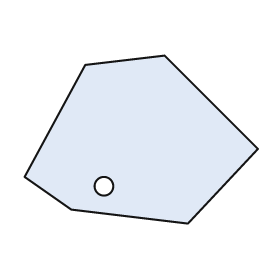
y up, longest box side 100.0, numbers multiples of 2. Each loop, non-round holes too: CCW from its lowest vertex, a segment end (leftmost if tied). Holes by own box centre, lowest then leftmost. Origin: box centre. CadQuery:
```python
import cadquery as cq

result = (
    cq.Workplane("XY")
    .moveTo(20.0, -36.0)
    .lineTo(50.0, -4.0)
    .lineTo(10.0, 36.0)
    .lineTo(-24.0, 32.0)
    .lineTo(-50.0, -16.0)
    .lineTo(-30.0, -30.0)
    .close()
    .moveTo(-16.0, -20.0)
    .circle(4.0)
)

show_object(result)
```